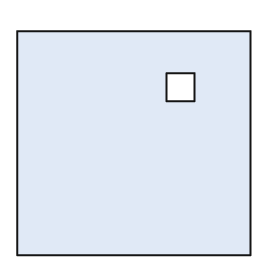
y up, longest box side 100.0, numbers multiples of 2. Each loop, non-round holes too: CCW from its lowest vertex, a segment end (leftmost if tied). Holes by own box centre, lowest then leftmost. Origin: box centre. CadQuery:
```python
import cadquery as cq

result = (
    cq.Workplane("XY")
    .moveTo(-50.0, -48.0)
    .lineTo(50.0, -48.0)
    .lineTo(50.0, 48.0)
    .lineTo(-50.0, 48.0)
    .close()
    .moveTo(14.0, 18.0)
    .lineTo(26.0, 18.0)
    .lineTo(26.0, 30.0)
    .lineTo(14.0, 30.0)
    .close()
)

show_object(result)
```